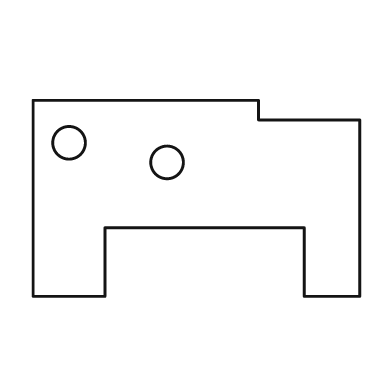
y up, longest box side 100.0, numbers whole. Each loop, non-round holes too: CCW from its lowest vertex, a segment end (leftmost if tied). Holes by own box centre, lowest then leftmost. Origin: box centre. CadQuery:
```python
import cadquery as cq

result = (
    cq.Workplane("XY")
    .moveTo(-50.0, -30.0)
    .lineTo(-28.0, -30.0)
    .lineTo(-28.0, -9.0)
    .lineTo(33.0, -9.0)
    .lineTo(33.0, -30.0)
    .lineTo(50.0, -30.0)
    .lineTo(50.0, 24.0)
    .lineTo(19.0, 24.0)
    .lineTo(19.0, 30.0)
    .lineTo(-50.0, 30.0)
    .close()
    .moveTo(-9.0, 11.0)
    .circle(5.0)
    .moveTo(-39.0, 17.0)
    .circle(5.0)
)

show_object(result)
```